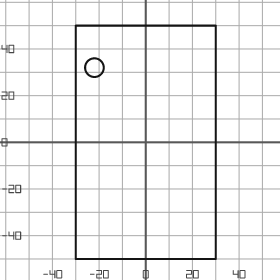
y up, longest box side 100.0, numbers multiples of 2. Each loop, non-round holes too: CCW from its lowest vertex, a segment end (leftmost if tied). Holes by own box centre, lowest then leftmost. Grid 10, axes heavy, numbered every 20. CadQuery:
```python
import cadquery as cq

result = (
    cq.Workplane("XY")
    .moveTo(-30.0, -50.0)
    .lineTo(30.0, -50.0)
    .lineTo(30.0, 50.0)
    .lineTo(-30.0, 50.0)
    .close()
    .moveTo(-22.0, 32.0)
    .circle(4.0)
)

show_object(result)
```